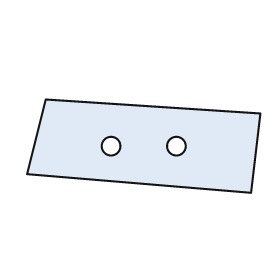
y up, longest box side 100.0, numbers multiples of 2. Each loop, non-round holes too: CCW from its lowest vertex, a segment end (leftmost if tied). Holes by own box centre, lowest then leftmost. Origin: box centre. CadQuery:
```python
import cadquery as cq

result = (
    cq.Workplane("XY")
    .moveTo(46.0, -20.0)
    .lineTo(50.0, 14.0)
    .lineTo(-42.0, 20.0)
    .lineTo(-50.0, -12.0)
    .close()
    .moveTo(-14.0, 0.0)
    .circle(4.0)
    .moveTo(14.0, 0.0)
    .circle(4.0)
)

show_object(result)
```